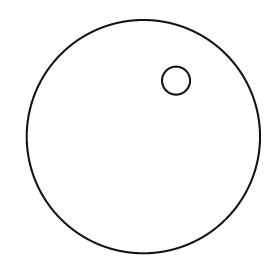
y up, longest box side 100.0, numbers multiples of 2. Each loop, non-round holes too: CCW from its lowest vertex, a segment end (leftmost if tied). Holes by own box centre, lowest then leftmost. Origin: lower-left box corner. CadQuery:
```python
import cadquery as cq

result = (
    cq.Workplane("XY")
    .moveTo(50.0, 50.0)
    .circle(50.0)
    .moveTo(64.0, 74.0)
    .circle(6.0)
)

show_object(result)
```